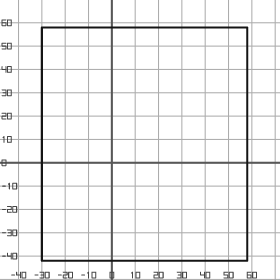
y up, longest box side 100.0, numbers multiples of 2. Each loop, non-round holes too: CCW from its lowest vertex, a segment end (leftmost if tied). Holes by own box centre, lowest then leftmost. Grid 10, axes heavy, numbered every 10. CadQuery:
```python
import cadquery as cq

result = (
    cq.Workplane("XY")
    .moveTo(-30.0, -42.0)
    .lineTo(58.0, -42.0)
    .lineTo(58.0, 58.0)
    .lineTo(-30.0, 58.0)
    .close()
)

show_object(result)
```